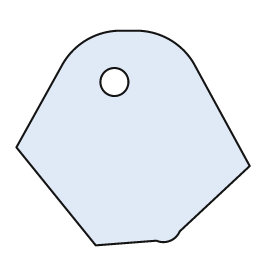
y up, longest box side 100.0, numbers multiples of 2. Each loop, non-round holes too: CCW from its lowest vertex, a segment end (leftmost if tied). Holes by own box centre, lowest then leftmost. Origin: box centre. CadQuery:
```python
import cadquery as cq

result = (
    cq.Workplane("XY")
    .moveTo(-16.0, -46.0)
    .lineTo(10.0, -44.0)
    .threePointArc((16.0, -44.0), (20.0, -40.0))
    .lineTo(50.0, -12.0)
    .lineTo(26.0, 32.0)
    .threePointArc((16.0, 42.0), (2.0, 46.0))
    .lineTo(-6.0, 46.0)
    .threePointArc((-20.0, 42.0), (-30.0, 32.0))
    .lineTo(-50.0, -4.0)
    .close()
    .moveTo(-8.0, 24.0)
    .circle(6.0)
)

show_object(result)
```